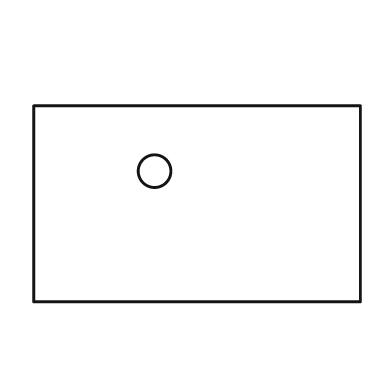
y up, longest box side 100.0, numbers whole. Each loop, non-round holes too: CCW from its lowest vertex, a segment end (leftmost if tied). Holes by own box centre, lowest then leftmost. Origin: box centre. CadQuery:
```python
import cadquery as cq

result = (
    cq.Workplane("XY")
    .moveTo(-50.0, -30.0)
    .lineTo(50.0, -30.0)
    .lineTo(50.0, 30.0)
    .lineTo(-50.0, 30.0)
    .close()
    .moveTo(-13.0, 10.0)
    .circle(5.0)
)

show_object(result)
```